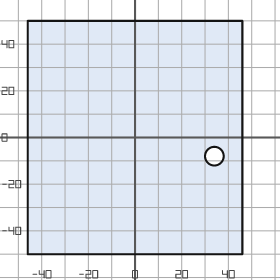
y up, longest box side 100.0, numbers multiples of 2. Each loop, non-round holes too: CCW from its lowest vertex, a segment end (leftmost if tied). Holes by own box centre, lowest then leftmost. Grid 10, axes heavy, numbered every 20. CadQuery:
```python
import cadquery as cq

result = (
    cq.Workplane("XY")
    .moveTo(-46.0, -50.0)
    .lineTo(46.0, -50.0)
    .lineTo(46.0, 50.0)
    .lineTo(-46.0, 50.0)
    .close()
    .moveTo(34.0, -8.0)
    .circle(4.0)
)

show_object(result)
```